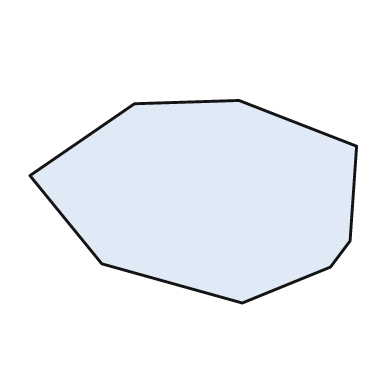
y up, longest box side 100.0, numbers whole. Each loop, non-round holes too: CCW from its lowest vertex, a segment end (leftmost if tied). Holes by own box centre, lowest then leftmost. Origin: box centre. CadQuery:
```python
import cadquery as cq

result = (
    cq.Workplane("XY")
    .moveTo(15.0, -31.0)
    .lineTo(42.0, -20.0)
    .lineTo(48.0, -12.0)
    .lineTo(50.0, 17.0)
    .lineTo(14.0, 31.0)
    .lineTo(-18.0, 30.0)
    .lineTo(-50.0, 8.0)
    .lineTo(-28.0, -19.0)
    .close()
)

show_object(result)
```